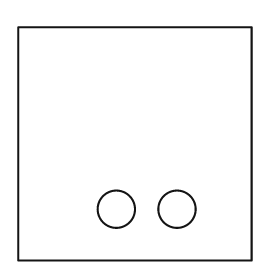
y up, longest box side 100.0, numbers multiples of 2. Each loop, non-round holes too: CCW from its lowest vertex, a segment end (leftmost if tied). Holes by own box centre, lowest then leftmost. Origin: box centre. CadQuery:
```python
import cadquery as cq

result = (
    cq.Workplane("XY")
    .moveTo(-50.0, -50.0)
    .lineTo(50.0, -50.0)
    .lineTo(50.0, 50.0)
    .lineTo(-50.0, 50.0)
    .close()
    .moveTo(-8.0, -28.0)
    .circle(8.0)
    .moveTo(18.0, -28.0)
    .circle(8.0)
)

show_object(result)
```